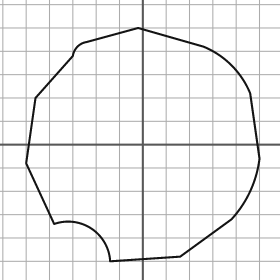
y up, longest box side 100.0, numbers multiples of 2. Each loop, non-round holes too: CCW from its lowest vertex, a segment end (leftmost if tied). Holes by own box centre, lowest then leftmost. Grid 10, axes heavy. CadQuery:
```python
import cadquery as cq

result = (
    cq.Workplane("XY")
    .moveTo(-14.0, -50.0)
    .lineTo(16.0, -48.0)
    .lineTo(38.0, -32.0)
    .threePointArc((46.0, -20.0), (50.0, -6.0))
    .lineTo(46.0, 22.0)
    .threePointArc((38.0, 34.0), (26.0, 42.0))
    .lineTo(-2.0, 50.0)
    .lineTo(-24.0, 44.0)
    .threePointArc((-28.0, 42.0), (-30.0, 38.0))
    .lineTo(-46.0, 20.0)
    .lineTo(-50.0, -8.0)
    .lineTo(-38.0, -34.0)
    .threePointArc((-22.0, -36.0), (-14.0, -50.0))
    .close()
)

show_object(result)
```